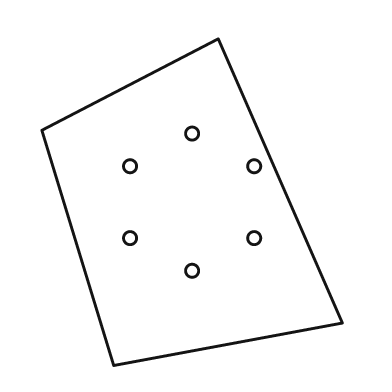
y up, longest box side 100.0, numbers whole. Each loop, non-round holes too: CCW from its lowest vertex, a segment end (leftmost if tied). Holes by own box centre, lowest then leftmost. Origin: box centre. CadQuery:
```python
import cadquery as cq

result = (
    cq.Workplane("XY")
    .moveTo(-24.0, -50.0)
    .lineTo(46.0, -37.0)
    .lineTo(8.0, 50.0)
    .lineTo(-46.0, 22.0)
    .close()
    .moveTo(0.0, -21.0)
    .circle(2.0)
    .moveTo(-19.0, -11.0)
    .circle(2.0)
    .moveTo(19.0, -11.0)
    .circle(2.0)
    .moveTo(-19.0, 11.0)
    .circle(2.0)
    .moveTo(19.0, 11.0)
    .circle(2.0)
    .moveTo(0.0, 21.0)
    .circle(2.0)
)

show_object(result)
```